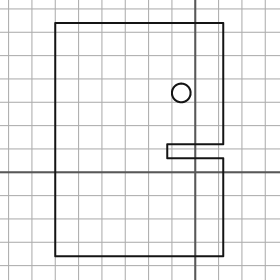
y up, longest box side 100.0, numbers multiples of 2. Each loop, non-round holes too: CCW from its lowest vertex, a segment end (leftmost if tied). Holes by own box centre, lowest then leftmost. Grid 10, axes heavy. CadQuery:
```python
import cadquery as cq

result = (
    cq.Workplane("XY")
    .moveTo(-60.0, -36.0)
    .lineTo(12.0, -36.0)
    .lineTo(12.0, 6.0)
    .lineTo(-12.0, 6.0)
    .lineTo(-12.0, 12.0)
    .lineTo(12.0, 12.0)
    .lineTo(12.0, 64.0)
    .lineTo(-60.0, 64.0)
    .close()
    .moveTo(-6.0, 34.0)
    .circle(4.0)
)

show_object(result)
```